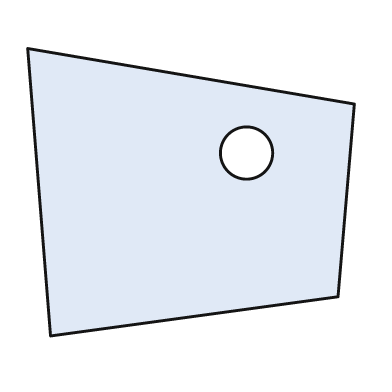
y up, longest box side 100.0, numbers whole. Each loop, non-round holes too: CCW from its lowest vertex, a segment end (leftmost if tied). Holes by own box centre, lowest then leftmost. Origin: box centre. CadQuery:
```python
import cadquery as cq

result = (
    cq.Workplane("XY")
    .moveTo(-43.0, -44.0)
    .lineTo(45.0, -32.0)
    .lineTo(50.0, 27.0)
    .lineTo(-50.0, 44.0)
    .close()
    .moveTo(17.0, 12.0)
    .circle(8.0)
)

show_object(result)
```